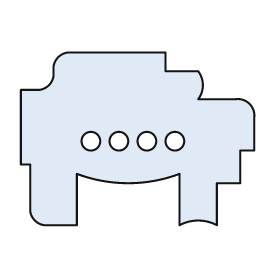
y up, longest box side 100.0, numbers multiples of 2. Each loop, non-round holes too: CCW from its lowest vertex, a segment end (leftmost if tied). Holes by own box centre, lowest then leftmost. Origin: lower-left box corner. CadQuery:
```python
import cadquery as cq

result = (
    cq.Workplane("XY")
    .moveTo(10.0, 0.0)
    .lineTo(24.0, 0.0)
    .lineTo(24.0, 22.0)
    .threePointArc((46.0, 18.0), (68.0, 22.0))
    .lineTo(68.0, 0.0)
    .threePointArc((76.0, 2.0), (84.0, 0.0))
    .lineTo(84.0, 18.0)
    .lineTo(94.0, 18.0)
    .lineTo(94.0, 32.0)
    .lineTo(100.0, 32.0)
    .lineTo(100.0, 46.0)
    .threePointArc((98.0, 52.0), (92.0, 54.0))
    .lineTo(76.0, 54.0)
    .threePointArc((78.0, 60.0), (76.0, 66.0))
    .lineTo(62.0, 66.0)
    .lineTo(62.0, 74.0)
    .lineTo(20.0, 74.0)
    .threePointArc((16.0, 72.0), (14.0, 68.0))
    .lineTo(14.0, 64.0)
    .threePointArc((12.0, 60.0), (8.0, 58.0))
    .lineTo(0.0, 58.0)
    .lineTo(0.0, 26.0)
    .lineTo(4.0, 26.0)
    .lineTo(4.0, 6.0)
    .threePointArc((6.0, 2.0), (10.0, 0.0))
    .close()
    .moveTo(30.0, 36.0)
    .circle(4.0)
    .moveTo(42.0, 36.0)
    .circle(4.0)
    .moveTo(54.0, 36.0)
    .circle(4.0)
    .moveTo(66.0, 36.0)
    .circle(4.0)
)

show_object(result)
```